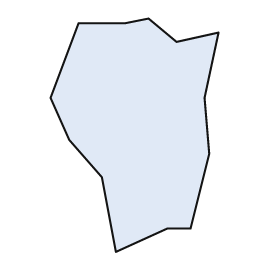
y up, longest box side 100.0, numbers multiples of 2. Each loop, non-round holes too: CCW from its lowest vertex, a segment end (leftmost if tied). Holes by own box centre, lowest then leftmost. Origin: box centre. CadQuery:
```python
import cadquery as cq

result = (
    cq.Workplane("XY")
    .moveTo(-8.0, -50.0)
    .lineTo(14.0, -40.0)
    .lineTo(24.0, -40.0)
    .lineTo(32.0, -8.0)
    .lineTo(30.0, 16.0)
    .lineTo(36.0, 44.0)
    .lineTo(18.0, 40.0)
    .lineTo(6.0, 50.0)
    .lineTo(-4.0, 48.0)
    .lineTo(-24.0, 48.0)
    .lineTo(-36.0, 16.0)
    .lineTo(-28.0, -2.0)
    .lineTo(-14.0, -18.0)
    .close()
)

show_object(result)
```